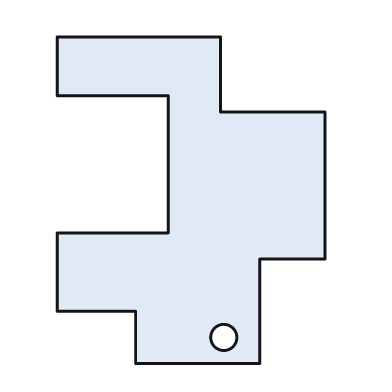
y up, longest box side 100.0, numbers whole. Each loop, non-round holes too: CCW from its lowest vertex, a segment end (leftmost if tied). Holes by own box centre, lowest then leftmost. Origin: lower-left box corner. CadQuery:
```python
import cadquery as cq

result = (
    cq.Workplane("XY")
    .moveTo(24.0, 0.0)
    .lineTo(62.0, 0.0)
    .lineTo(62.0, 32.0)
    .lineTo(82.0, 32.0)
    .lineTo(82.0, 77.0)
    .lineTo(50.0, 77.0)
    .lineTo(50.0, 100.0)
    .lineTo(0.0, 100.0)
    .lineTo(0.0, 82.0)
    .lineTo(34.0, 82.0)
    .lineTo(34.0, 40.0)
    .lineTo(0.0, 40.0)
    .lineTo(0.0, 16.0)
    .lineTo(24.0, 16.0)
    .close()
    .moveTo(51.0, 8.0)
    .circle(4.0)
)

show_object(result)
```